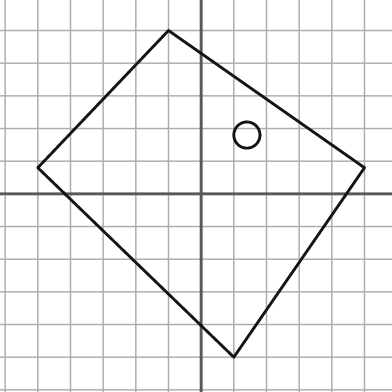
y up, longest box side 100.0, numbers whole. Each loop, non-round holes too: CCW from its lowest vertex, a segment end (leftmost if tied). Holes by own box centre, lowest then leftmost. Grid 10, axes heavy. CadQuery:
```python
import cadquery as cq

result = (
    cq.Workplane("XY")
    .moveTo(10.0, -50.0)
    .lineTo(50.0, 8.0)
    .lineTo(-10.0, 50.0)
    .lineTo(-50.0, 8.0)
    .close()
    .moveTo(14.0, 18.0)
    .circle(4.0)
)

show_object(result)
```